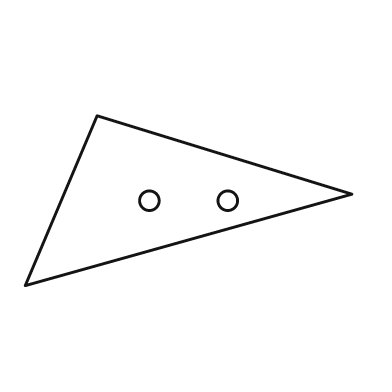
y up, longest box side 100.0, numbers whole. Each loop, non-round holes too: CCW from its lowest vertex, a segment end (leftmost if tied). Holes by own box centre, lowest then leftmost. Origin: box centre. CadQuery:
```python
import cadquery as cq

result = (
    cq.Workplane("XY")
    .moveTo(-50.0, -26.0)
    .lineTo(50.0, 2.0)
    .lineTo(-28.0, 26.0)
    .close()
    .moveTo(-12.0, 0.0)
    .circle(3.0)
    .moveTo(12.0, 0.0)
    .circle(3.0)
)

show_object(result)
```